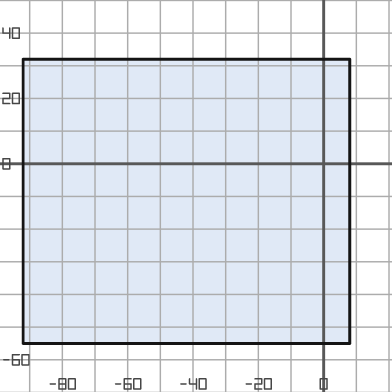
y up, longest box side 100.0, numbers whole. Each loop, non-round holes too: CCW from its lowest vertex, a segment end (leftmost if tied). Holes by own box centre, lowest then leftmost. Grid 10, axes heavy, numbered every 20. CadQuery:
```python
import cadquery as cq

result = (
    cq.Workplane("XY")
    .moveTo(-92.0, -55.0)
    .lineTo(8.0, -55.0)
    .lineTo(8.0, 32.0)
    .lineTo(-92.0, 32.0)
    .close()
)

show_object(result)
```